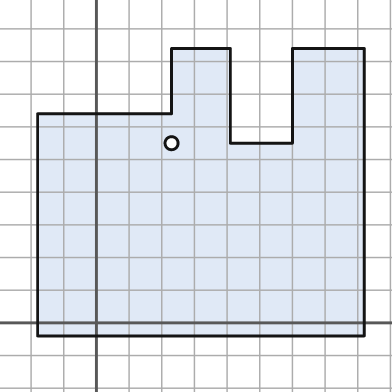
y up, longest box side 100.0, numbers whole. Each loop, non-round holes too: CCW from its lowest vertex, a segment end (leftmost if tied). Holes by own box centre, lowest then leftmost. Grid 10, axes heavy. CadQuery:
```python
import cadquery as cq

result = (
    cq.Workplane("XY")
    .moveTo(-18.0, -4.0)
    .lineTo(82.0, -4.0)
    .lineTo(82.0, 84.0)
    .lineTo(60.0, 84.0)
    .lineTo(60.0, 55.0)
    .lineTo(41.0, 55.0)
    .lineTo(41.0, 84.0)
    .lineTo(23.0, 84.0)
    .lineTo(23.0, 64.0)
    .lineTo(-18.0, 64.0)
    .close()
    .moveTo(23.0, 55.0)
    .circle(2.0)
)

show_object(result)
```